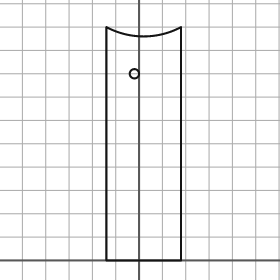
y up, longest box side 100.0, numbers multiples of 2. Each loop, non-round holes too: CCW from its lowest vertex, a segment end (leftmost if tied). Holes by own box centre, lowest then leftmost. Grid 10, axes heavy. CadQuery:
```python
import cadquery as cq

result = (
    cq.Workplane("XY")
    .moveTo(-14.0, 0.0)
    .lineTo(18.0, 0.0)
    .lineTo(18.0, 100.0)
    .threePointArc((2.0, 96.0), (-14.0, 100.0))
    .close()
    .moveTo(-2.0, 80.0)
    .circle(2.0)
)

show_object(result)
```